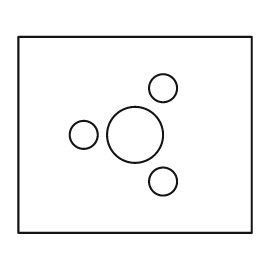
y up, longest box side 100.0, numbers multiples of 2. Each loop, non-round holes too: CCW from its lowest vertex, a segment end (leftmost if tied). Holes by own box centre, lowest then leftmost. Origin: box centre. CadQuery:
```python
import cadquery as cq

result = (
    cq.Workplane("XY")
    .moveTo(-50.0, -42.0)
    .lineTo(50.0, -42.0)
    .lineTo(50.0, 42.0)
    .lineTo(-50.0, 42.0)
    .close()
    .moveTo(12.0, -20.0)
    .circle(6.0)
    .moveTo(-22.0, 0.0)
    .circle(6.0)
    .moveTo(0.0, 0.0)
    .circle(12.0)
    .moveTo(12.0, 20.0)
    .circle(6.0)
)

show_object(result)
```